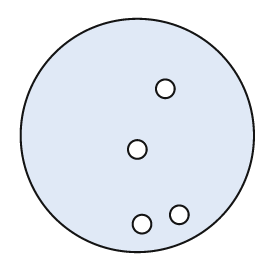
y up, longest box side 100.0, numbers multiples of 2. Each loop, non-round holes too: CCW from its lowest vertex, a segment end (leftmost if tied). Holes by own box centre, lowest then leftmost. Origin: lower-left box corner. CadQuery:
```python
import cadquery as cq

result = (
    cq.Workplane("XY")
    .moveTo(50.0, 50.0)
    .circle(50.0)
    .moveTo(52.0, 12.0)
    .circle(4.0)
    .moveTo(68.0, 16.0)
    .circle(4.0)
    .moveTo(50.0, 44.0)
    .circle(4.0)
    .moveTo(62.0, 70.0)
    .circle(4.0)
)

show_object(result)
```